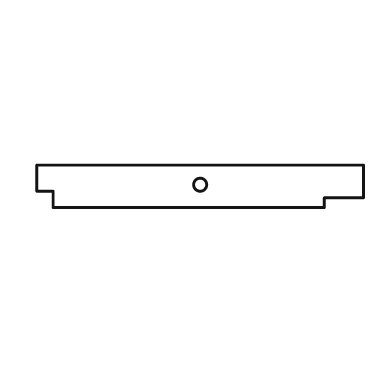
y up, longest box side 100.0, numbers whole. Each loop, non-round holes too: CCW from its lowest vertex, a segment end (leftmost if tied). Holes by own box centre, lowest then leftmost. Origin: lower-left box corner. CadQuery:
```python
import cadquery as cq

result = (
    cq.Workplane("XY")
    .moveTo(5.0, 0.0)
    .lineTo(88.0, 0.0)
    .lineTo(88.0, 3.0)
    .lineTo(100.0, 3.0)
    .lineTo(100.0, 13.0)
    .lineTo(0.0, 13.0)
    .lineTo(0.0, 5.0)
    .lineTo(5.0, 5.0)
    .close()
    .moveTo(50.0, 7.0)
    .circle(2.0)
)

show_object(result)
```